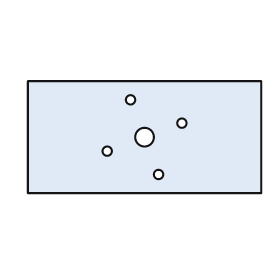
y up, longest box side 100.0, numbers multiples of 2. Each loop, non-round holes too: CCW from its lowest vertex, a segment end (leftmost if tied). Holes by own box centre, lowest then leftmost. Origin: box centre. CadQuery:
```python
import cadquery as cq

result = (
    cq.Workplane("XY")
    .moveTo(-50.0, -24.0)
    .lineTo(50.0, -24.0)
    .lineTo(50.0, 24.0)
    .lineTo(-50.0, 24.0)
    .close()
    .moveTo(6.0, -16.0)
    .circle(2.0)
    .moveTo(-16.0, -6.0)
    .circle(2.0)
    .moveTo(0.0, 0.0)
    .circle(4.0)
    .moveTo(16.0, 6.0)
    .circle(2.0)
    .moveTo(-6.0, 16.0)
    .circle(2.0)
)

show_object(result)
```